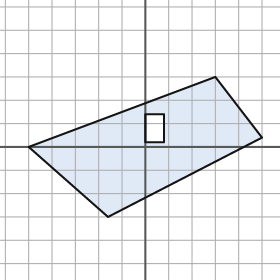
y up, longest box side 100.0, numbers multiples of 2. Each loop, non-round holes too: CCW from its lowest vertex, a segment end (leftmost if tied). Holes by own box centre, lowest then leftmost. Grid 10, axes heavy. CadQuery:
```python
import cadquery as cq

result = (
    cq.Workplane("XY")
    .moveTo(-16.0, -30.0)
    .lineTo(50.0, 4.0)
    .lineTo(30.0, 30.0)
    .lineTo(-50.0, 0.0)
    .close()
    .moveTo(0.0, 2.0)
    .lineTo(8.0, 2.0)
    .lineTo(8.0, 14.0)
    .lineTo(0.0, 14.0)
    .close()
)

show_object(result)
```